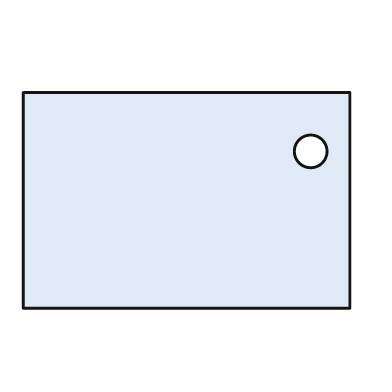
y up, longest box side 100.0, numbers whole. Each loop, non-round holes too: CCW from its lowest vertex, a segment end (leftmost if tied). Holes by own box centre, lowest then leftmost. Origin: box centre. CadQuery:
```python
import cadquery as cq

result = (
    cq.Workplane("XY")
    .moveTo(-50.0, -33.0)
    .lineTo(50.0, -33.0)
    .lineTo(50.0, 33.0)
    .lineTo(-50.0, 33.0)
    .close()
    .moveTo(38.0, 15.0)
    .circle(5.0)
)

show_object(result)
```